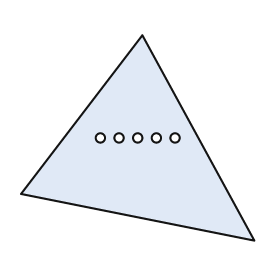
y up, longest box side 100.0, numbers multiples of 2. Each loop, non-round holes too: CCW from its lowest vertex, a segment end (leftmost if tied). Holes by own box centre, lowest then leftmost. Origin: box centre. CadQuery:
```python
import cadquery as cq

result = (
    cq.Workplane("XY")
    .moveTo(50.0, -44.0)
    .lineTo(2.0, 44.0)
    .lineTo(-50.0, -24.0)
    .close()
    .moveTo(-16.0, 0.0)
    .circle(2.0)
    .moveTo(-8.0, 0.0)
    .circle(2.0)
    .moveTo(0.0, 0.0)
    .circle(2.0)
    .moveTo(8.0, 0.0)
    .circle(2.0)
    .moveTo(16.0, 0.0)
    .circle(2.0)
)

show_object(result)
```